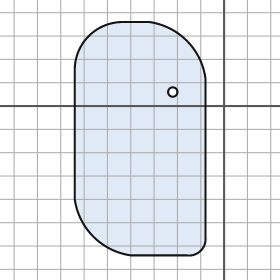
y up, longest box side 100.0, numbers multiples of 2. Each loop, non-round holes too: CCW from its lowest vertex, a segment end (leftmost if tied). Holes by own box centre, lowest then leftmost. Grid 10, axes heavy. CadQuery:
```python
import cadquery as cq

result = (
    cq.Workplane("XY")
    .moveTo(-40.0, -64.0)
    .lineTo(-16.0, -64.0)
    .threePointArc((-10.0, -62.0), (-8.0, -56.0))
    .lineTo(-8.0, 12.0)
    .threePointArc((-16.0, 28.0), (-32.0, 36.0))
    .lineTo(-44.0, 36.0)
    .threePointArc((-58.0, 30.0), (-64.0, 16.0))
    .lineTo(-64.0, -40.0)
    .threePointArc((-56.0, -56.0), (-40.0, -64.0))
    .close()
    .moveTo(-22.0, 6.0)
    .circle(2.0)
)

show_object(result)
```